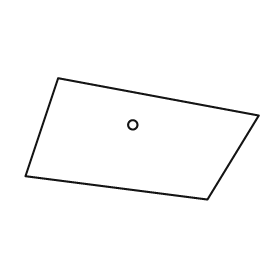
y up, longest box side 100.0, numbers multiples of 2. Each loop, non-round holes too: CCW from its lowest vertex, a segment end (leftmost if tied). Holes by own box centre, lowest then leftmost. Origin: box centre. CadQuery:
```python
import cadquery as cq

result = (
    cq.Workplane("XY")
    .moveTo(28.0, -26.0)
    .lineTo(50.0, 10.0)
    .lineTo(-36.0, 26.0)
    .lineTo(-50.0, -16.0)
    .close()
    .moveTo(-4.0, 6.0)
    .circle(2.0)
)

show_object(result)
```